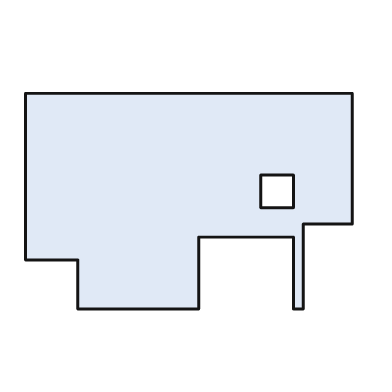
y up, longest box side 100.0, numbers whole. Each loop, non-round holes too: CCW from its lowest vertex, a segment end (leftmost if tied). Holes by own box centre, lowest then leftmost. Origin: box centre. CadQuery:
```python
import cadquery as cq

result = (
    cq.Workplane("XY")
    .moveTo(-34.0, -33.0)
    .lineTo(3.0, -33.0)
    .lineTo(3.0, -11.0)
    .lineTo(32.0, -11.0)
    .lineTo(32.0, -33.0)
    .lineTo(35.0, -33.0)
    .lineTo(35.0, -7.0)
    .lineTo(50.0, -7.0)
    .lineTo(50.0, 33.0)
    .lineTo(-50.0, 33.0)
    .lineTo(-50.0, -18.0)
    .lineTo(-34.0, -18.0)
    .close()
    .moveTo(22.0, -2.0)
    .lineTo(32.0, -2.0)
    .lineTo(32.0, 8.0)
    .lineTo(22.0, 8.0)
    .close()
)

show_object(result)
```